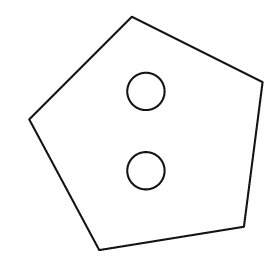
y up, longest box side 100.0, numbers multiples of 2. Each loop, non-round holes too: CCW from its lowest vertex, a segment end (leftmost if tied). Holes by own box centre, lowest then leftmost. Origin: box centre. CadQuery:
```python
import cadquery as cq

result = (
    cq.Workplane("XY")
    .moveTo(-20.0, -50.0)
    .lineTo(42.0, -40.0)
    .lineTo(50.0, 22.0)
    .lineTo(-6.0, 50.0)
    .lineTo(-50.0, 6.0)
    .close()
    .moveTo(0.0, -16.0)
    .circle(8.0)
    .moveTo(0.0, 18.0)
    .circle(8.0)
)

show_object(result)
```